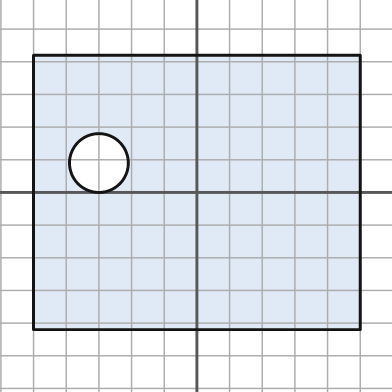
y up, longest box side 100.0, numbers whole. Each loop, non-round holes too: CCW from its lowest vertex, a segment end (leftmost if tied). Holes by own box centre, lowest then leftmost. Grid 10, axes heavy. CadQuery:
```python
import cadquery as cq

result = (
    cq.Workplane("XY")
    .moveTo(-50.0, -42.0)
    .lineTo(50.0, -42.0)
    .lineTo(50.0, 42.0)
    .lineTo(-50.0, 42.0)
    .close()
    .moveTo(-30.0, 9.0)
    .circle(9.0)
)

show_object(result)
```